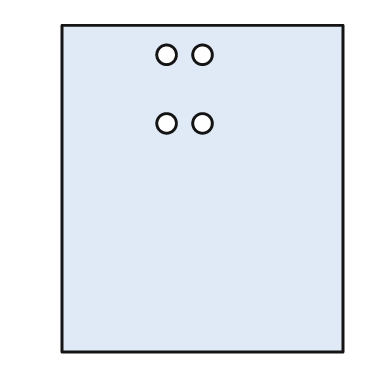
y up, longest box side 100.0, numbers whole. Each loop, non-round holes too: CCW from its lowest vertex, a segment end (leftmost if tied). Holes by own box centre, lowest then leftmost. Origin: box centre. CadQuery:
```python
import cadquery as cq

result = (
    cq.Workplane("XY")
    .moveTo(-43.0, -50.0)
    .lineTo(43.0, -50.0)
    .lineTo(43.0, 50.0)
    .lineTo(-43.0, 50.0)
    .close()
    .moveTo(-11.0, 20.0)
    .circle(3.0)
    .moveTo(0.0, 20.0)
    .circle(3.0)
    .moveTo(-11.0, 41.0)
    .circle(3.0)
    .moveTo(0.0, 41.0)
    .circle(3.0)
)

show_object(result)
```